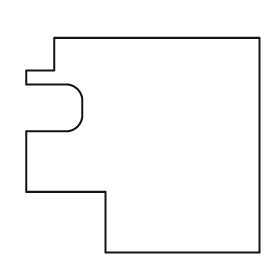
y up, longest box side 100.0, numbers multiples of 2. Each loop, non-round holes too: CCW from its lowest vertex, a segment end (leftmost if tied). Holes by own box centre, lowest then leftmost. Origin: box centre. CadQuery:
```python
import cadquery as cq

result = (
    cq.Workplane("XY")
    .moveTo(-16.0, -46.0)
    .lineTo(50.0, -46.0)
    .lineTo(50.0, 46.0)
    .lineTo(-38.0, 46.0)
    .lineTo(-38.0, 32.0)
    .lineTo(-50.0, 32.0)
    .lineTo(-50.0, 26.0)
    .lineTo(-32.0, 26.0)
    .threePointArc((-28.0, 24.0), (-26.0, 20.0))
    .lineTo(-26.0, 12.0)
    .threePointArc((-28.0, 8.0), (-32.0, 6.0))
    .lineTo(-50.0, 6.0)
    .lineTo(-50.0, -20.0)
    .lineTo(-16.0, -20.0)
    .close()
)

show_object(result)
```